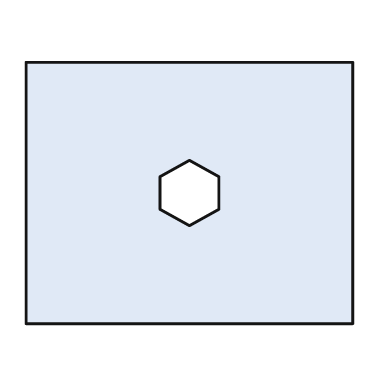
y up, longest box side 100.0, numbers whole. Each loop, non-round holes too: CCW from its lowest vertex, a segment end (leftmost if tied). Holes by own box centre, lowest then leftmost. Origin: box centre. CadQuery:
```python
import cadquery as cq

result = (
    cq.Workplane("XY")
    .moveTo(-50.0, -40.0)
    .lineTo(50.0, -40.0)
    .lineTo(50.0, 40.0)
    .lineTo(-50.0, 40.0)
    .close()
    .moveTo(0.0, -10.0)
    .lineTo(9.0, -5.0)
    .lineTo(9.0, 5.0)
    .lineTo(0.0, 10.0)
    .lineTo(-9.0, 5.0)
    .lineTo(-9.0, -5.0)
    .close()
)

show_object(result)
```